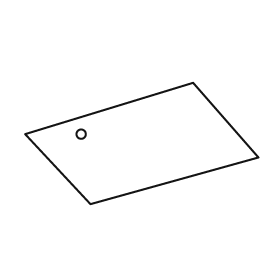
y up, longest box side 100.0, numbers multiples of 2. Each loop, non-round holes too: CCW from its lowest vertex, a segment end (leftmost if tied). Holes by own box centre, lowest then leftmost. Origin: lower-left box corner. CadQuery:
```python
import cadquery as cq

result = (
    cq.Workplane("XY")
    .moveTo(28.0, 0.0)
    .lineTo(100.0, 20.0)
    .lineTo(72.0, 52.0)
    .lineTo(0.0, 30.0)
    .close()
    .moveTo(24.0, 30.0)
    .circle(2.0)
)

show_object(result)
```